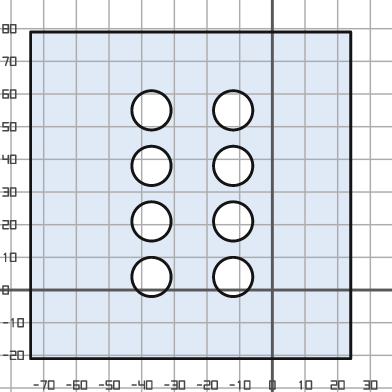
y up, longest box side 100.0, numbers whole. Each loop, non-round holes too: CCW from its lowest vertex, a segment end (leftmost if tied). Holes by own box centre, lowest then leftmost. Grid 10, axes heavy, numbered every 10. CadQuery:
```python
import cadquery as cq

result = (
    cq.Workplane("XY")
    .moveTo(-74.0, -21.0)
    .lineTo(24.0, -21.0)
    .lineTo(24.0, 79.0)
    .lineTo(-74.0, 79.0)
    .close()
    .moveTo(-37.0, 4.0)
    .circle(6.0)
    .moveTo(-12.0, 4.0)
    .circle(6.0)
    .moveTo(-37.0, 21.0)
    .circle(6.0)
    .moveTo(-12.0, 21.0)
    .circle(6.0)
    .moveTo(-37.0, 38.0)
    .circle(6.0)
    .moveTo(-12.0, 38.0)
    .circle(6.0)
    .moveTo(-37.0, 55.0)
    .circle(6.0)
    .moveTo(-12.0, 55.0)
    .circle(6.0)
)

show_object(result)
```